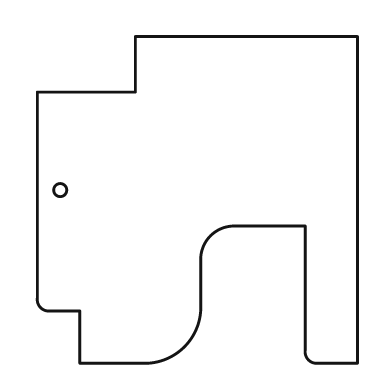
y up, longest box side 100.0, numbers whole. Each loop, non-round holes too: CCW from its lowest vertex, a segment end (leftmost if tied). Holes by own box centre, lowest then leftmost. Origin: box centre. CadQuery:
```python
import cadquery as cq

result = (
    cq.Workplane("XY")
    .moveTo(-36.0, -50.0)
    .lineTo(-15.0, -50.0)
    .threePointArc((-4.0, -45.0), (1.0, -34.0))
    .lineTo(1.0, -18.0)
    .threePointArc((4.0, -11.0), (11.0, -8.0))
    .lineTo(33.0, -8.0)
    .lineTo(33.0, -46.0)
    .threePointArc((34.0, -49.0), (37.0, -50.0))
    .lineTo(49.0, -50.0)
    .lineTo(49.0, 50.0)
    .lineTo(-19.0, 50.0)
    .lineTo(-19.0, 33.0)
    .lineTo(-49.0, 33.0)
    .lineTo(-49.0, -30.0)
    .threePointArc((-48.0, -33.0), (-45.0, -34.0))
    .lineTo(-36.0, -34.0)
    .close()
    .moveTo(-42.0, 3.0)
    .circle(2.0)
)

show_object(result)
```